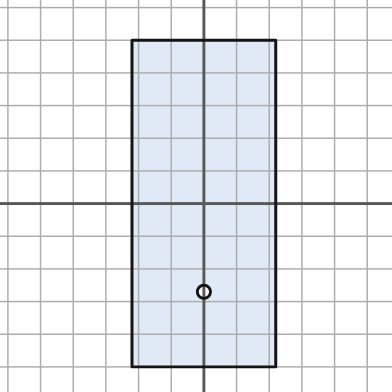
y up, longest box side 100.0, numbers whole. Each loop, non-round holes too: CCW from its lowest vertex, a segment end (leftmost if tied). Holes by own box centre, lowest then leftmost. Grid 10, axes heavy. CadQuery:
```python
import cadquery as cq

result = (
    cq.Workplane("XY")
    .moveTo(-22.0, -50.0)
    .lineTo(22.0, -50.0)
    .lineTo(22.0, 50.0)
    .lineTo(-22.0, 50.0)
    .close()
    .moveTo(0.0, -27.0)
    .circle(2.0)
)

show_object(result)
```